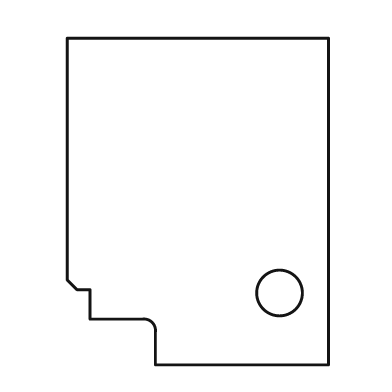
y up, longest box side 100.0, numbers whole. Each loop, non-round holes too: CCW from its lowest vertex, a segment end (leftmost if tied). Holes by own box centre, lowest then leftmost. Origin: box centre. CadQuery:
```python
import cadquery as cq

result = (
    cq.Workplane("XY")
    .moveTo(-13.0, -50.0)
    .lineTo(40.0, -50.0)
    .lineTo(40.0, 50.0)
    .lineTo(-40.0, 50.0)
    .lineTo(-40.0, -24.0)
    .lineTo(-37.0, -27.0)
    .lineTo(-33.0, -27.0)
    .lineTo(-33.0, -36.0)
    .lineTo(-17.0, -36.0)
    .threePointArc((-14.0, -37.0), (-13.0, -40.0))
    .close()
    .moveTo(25.0, -28.0)
    .circle(7.0)
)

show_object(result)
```